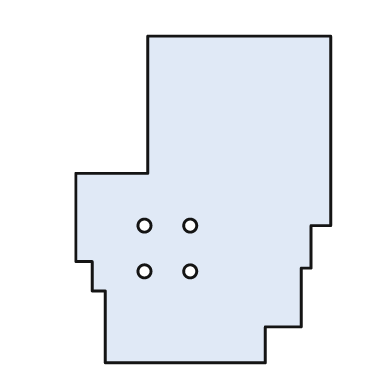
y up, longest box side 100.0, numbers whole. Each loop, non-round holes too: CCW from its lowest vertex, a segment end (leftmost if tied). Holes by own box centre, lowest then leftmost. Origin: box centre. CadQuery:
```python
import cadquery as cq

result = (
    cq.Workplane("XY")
    .moveTo(-30.0, -50.0)
    .lineTo(19.0, -50.0)
    .lineTo(19.0, -39.0)
    .lineTo(30.0, -39.0)
    .lineTo(30.0, -21.0)
    .lineTo(33.0, -21.0)
    .lineTo(33.0, -8.0)
    .lineTo(39.0, -8.0)
    .lineTo(39.0, 50.0)
    .lineTo(-17.0, 50.0)
    .lineTo(-17.0, 8.0)
    .lineTo(-39.0, 8.0)
    .lineTo(-39.0, -19.0)
    .lineTo(-34.0, -19.0)
    .lineTo(-34.0, -28.0)
    .lineTo(-30.0, -28.0)
    .close()
    .moveTo(-18.0, -22.0)
    .circle(2.0)
    .moveTo(-4.0, -22.0)
    .circle(2.0)
    .moveTo(-18.0, -8.0)
    .circle(2.0)
    .moveTo(-4.0, -8.0)
    .circle(2.0)
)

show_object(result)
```